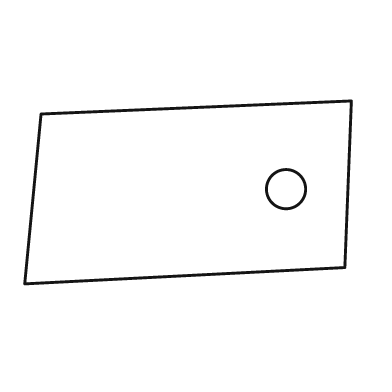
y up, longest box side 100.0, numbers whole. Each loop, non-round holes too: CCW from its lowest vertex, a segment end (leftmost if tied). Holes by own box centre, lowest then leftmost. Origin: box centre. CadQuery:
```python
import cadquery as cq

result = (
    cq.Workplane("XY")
    .moveTo(-50.0, -28.0)
    .lineTo(48.0, -23.0)
    .lineTo(50.0, 28.0)
    .lineTo(-45.0, 24.0)
    .close()
    .moveTo(30.0, 1.0)
    .circle(6.0)
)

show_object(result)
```